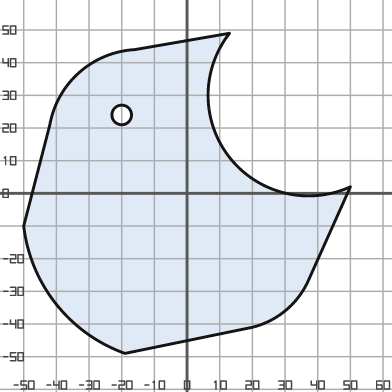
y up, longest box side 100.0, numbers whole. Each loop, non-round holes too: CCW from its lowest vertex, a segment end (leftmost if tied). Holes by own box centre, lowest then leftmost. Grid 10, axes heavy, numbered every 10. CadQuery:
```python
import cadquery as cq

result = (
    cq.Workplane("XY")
    .moveTo(-19.0, -49.0)
    .lineTo(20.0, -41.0)
    .threePointArc((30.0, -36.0), (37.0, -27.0))
    .lineTo(50.0, 2.0)
    .threePointArc((13.0, 11.0), (13.0, 49.0))
    .lineTo(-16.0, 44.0)
    .threePointArc((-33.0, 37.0), (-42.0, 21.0))
    .lineTo(-50.0, -10.0)
    .threePointArc((-40.0, -34.0), (-19.0, -49.0))
    .close()
    .moveTo(-20.0, 24.0)
    .circle(3.0)
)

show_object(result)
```